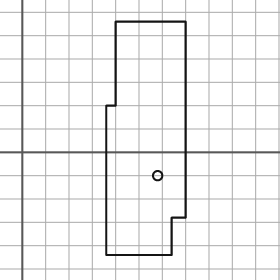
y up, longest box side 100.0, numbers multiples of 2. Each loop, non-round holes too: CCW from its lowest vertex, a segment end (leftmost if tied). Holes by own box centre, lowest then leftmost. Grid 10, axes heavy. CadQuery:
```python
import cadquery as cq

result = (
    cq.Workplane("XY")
    .moveTo(36.0, -44.0)
    .lineTo(64.0, -44.0)
    .lineTo(64.0, -28.0)
    .lineTo(70.0, -28.0)
    .lineTo(70.0, 56.0)
    .lineTo(40.0, 56.0)
    .lineTo(40.0, 20.0)
    .lineTo(36.0, 20.0)
    .close()
    .moveTo(58.0, -10.0)
    .circle(2.0)
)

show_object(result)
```